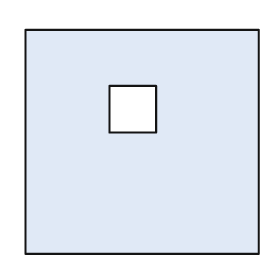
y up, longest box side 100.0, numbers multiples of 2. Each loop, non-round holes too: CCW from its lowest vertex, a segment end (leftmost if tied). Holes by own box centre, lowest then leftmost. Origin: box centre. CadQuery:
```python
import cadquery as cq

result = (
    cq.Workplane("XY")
    .moveTo(-50.0, -48.0)
    .lineTo(50.0, -48.0)
    .lineTo(50.0, 48.0)
    .lineTo(-50.0, 48.0)
    .close()
    .moveTo(-14.0, 4.0)
    .lineTo(6.0, 4.0)
    .lineTo(6.0, 24.0)
    .lineTo(-14.0, 24.0)
    .close()
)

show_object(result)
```